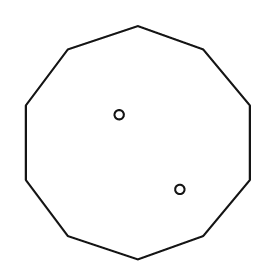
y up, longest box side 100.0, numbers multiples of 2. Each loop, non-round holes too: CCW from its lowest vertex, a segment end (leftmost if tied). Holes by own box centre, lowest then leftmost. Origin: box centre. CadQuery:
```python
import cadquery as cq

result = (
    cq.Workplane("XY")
    .moveTo(0.0, -50.0)
    .lineTo(28.0, -40.0)
    .lineTo(48.0, -16.0)
    .lineTo(48.0, 16.0)
    .lineTo(28.0, 40.0)
    .lineTo(0.0, 50.0)
    .lineTo(-30.0, 40.0)
    .lineTo(-48.0, 16.0)
    .lineTo(-48.0, -16.0)
    .lineTo(-30.0, -40.0)
    .close()
    .moveTo(18.0, -20.0)
    .circle(2.0)
    .moveTo(-8.0, 12.0)
    .circle(2.0)
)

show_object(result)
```